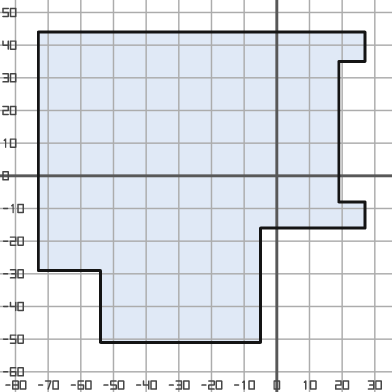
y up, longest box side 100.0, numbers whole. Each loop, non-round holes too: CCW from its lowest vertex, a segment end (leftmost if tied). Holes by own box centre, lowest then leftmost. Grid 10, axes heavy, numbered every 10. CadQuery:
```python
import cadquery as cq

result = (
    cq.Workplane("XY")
    .moveTo(-54.0, -51.0)
    .lineTo(-5.0, -51.0)
    .lineTo(-5.0, -16.0)
    .lineTo(27.0, -16.0)
    .lineTo(27.0, -8.0)
    .lineTo(19.0, -8.0)
    .lineTo(19.0, 35.0)
    .lineTo(27.0, 35.0)
    .lineTo(27.0, 44.0)
    .lineTo(-73.0, 44.0)
    .lineTo(-73.0, -29.0)
    .lineTo(-54.0, -29.0)
    .close()
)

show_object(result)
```